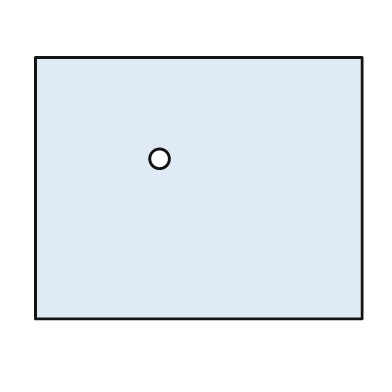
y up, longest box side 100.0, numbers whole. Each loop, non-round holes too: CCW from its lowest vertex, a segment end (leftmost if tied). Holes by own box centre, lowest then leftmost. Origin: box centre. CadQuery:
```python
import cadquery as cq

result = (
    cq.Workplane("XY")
    .moveTo(-50.0, -40.0)
    .lineTo(50.0, -40.0)
    .lineTo(50.0, 40.0)
    .lineTo(-50.0, 40.0)
    .close()
    .moveTo(-12.0, 9.0)
    .circle(3.0)
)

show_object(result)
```